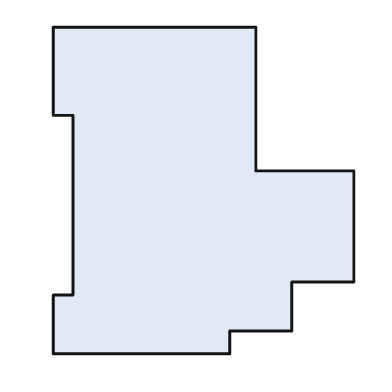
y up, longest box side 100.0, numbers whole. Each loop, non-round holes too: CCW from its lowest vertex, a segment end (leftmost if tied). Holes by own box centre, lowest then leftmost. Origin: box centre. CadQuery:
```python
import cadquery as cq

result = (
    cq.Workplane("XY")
    .moveTo(-46.0, -50.0)
    .lineTo(8.0, -50.0)
    .lineTo(8.0, -43.0)
    .lineTo(27.0, -43.0)
    .lineTo(27.0, -28.0)
    .lineTo(46.0, -28.0)
    .lineTo(46.0, 6.0)
    .lineTo(16.0, 6.0)
    .lineTo(16.0, 50.0)
    .lineTo(-46.0, 50.0)
    .lineTo(-46.0, 23.0)
    .lineTo(-40.0, 23.0)
    .lineTo(-40.0, -32.0)
    .lineTo(-46.0, -32.0)
    .close()
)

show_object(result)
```